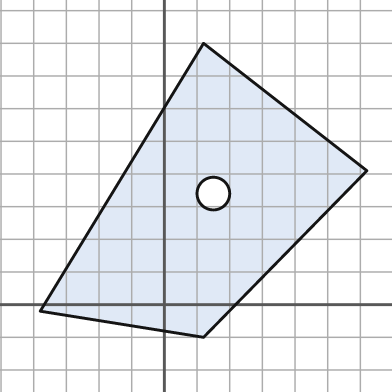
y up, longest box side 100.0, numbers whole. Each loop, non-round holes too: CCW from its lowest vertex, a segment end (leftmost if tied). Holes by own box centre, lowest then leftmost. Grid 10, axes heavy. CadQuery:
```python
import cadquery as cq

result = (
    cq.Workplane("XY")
    .moveTo(12.0, -10.0)
    .lineTo(62.0, 41.0)
    .lineTo(12.0, 80.0)
    .lineTo(-38.0, -2.0)
    .close()
    .moveTo(15.0, 34.0)
    .circle(5.0)
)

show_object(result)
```